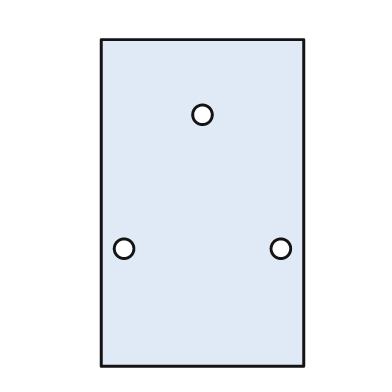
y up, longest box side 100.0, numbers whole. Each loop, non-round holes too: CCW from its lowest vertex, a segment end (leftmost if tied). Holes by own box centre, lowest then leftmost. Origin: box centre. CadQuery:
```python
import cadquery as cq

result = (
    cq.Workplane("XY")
    .moveTo(-31.0, -50.0)
    .lineTo(31.0, -50.0)
    .lineTo(31.0, 50.0)
    .lineTo(-31.0, 50.0)
    .close()
    .moveTo(-24.0, -14.0)
    .circle(3.0)
    .moveTo(24.0, -14.0)
    .circle(3.0)
    .moveTo(0.0, 27.0)
    .circle(3.0)
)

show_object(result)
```